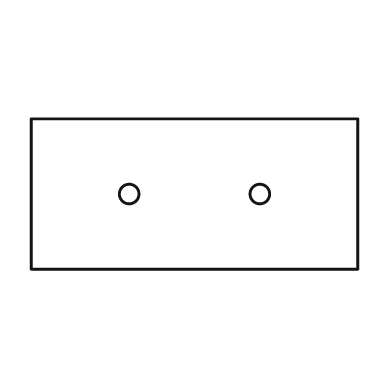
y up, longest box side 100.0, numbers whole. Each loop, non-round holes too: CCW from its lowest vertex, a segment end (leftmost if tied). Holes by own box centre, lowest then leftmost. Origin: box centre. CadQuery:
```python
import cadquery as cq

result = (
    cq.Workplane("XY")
    .moveTo(-50.0, -23.0)
    .lineTo(50.0, -23.0)
    .lineTo(50.0, 23.0)
    .lineTo(-50.0, 23.0)
    .close()
    .moveTo(-20.0, 0.0)
    .circle(3.0)
    .moveTo(20.0, 0.0)
    .circle(3.0)
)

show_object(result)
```